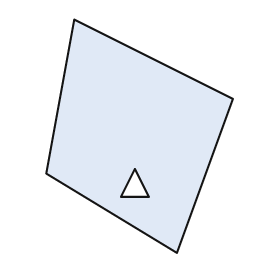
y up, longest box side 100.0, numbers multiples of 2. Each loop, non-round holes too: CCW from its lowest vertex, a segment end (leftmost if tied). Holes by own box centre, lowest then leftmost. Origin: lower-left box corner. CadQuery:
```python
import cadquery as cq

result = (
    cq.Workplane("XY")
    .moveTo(56.0, 0.0)
    .lineTo(80.0, 66.0)
    .lineTo(12.0, 100.0)
    .lineTo(0.0, 34.0)
    .close()
    .moveTo(32.0, 24.0)
    .lineTo(44.0, 24.0)
    .lineTo(38.0, 36.0)
    .close()
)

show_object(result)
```